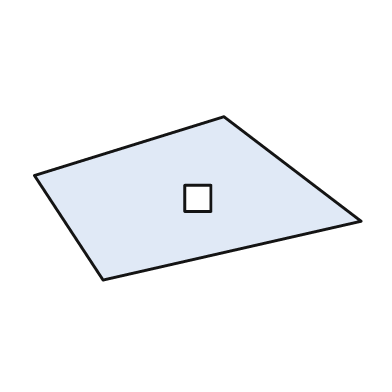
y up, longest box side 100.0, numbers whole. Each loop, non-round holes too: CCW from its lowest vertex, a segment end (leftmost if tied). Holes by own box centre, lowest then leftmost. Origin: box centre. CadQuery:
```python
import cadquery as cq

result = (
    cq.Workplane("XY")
    .moveTo(-29.0, -25.0)
    .lineTo(50.0, -7.0)
    .lineTo(8.0, 25.0)
    .lineTo(-50.0, 7.0)
    .close()
    .moveTo(-4.0, -4.0)
    .lineTo(4.0, -4.0)
    .lineTo(4.0, 4.0)
    .lineTo(-4.0, 4.0)
    .close()
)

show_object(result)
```